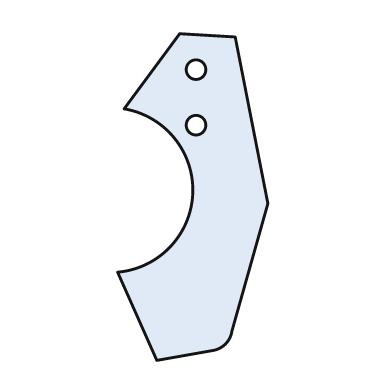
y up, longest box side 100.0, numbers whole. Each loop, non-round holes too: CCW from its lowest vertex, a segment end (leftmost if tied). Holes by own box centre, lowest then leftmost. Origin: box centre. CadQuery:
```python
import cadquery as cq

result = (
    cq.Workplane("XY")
    .moveTo(-11.0, -50.0)
    .lineTo(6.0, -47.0)
    .threePointArc((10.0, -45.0), (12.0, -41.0))
    .lineTo(23.0, -2.0)
    .lineTo(13.0, 49.0)
    .lineTo(-4.0, 50.0)
    .lineTo(-21.0, 27.0)
    .threePointArc((0.0, 1.0), (-23.0, -23.0))
    .close()
    .moveTo(1.0, 22.0)
    .circle(3.0)
    .moveTo(1.0, 39.0)
    .circle(3.0)
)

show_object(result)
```